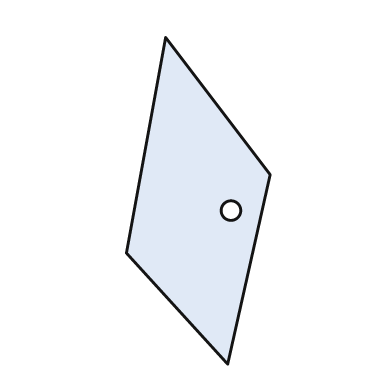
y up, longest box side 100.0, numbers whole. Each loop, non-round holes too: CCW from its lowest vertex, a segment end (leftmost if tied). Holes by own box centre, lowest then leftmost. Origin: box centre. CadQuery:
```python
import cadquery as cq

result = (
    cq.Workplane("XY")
    .moveTo(9.0, -50.0)
    .lineTo(22.0, 8.0)
    .lineTo(-10.0, 50.0)
    .lineTo(-22.0, -16.0)
    .close()
    .moveTo(10.0, -3.0)
    .circle(3.0)
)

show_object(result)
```